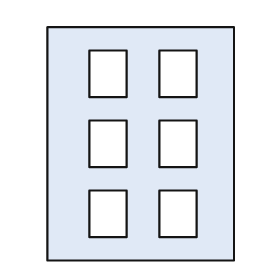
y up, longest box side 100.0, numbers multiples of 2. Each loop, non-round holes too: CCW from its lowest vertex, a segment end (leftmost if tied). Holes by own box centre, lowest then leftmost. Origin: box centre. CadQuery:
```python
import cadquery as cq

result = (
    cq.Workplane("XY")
    .moveTo(-40.0, -50.0)
    .lineTo(40.0, -50.0)
    .lineTo(40.0, 50.0)
    .lineTo(-40.0, 50.0)
    .close()
    .moveTo(-22.0, -40.0)
    .lineTo(-6.0, -40.0)
    .lineTo(-6.0, -20.0)
    .lineTo(-22.0, -20.0)
    .close()
    .moveTo(8.0, -40.0)
    .lineTo(24.0, -40.0)
    .lineTo(24.0, -20.0)
    .lineTo(8.0, -20.0)
    .close()
    .moveTo(-22.0, -10.0)
    .lineTo(-6.0, -10.0)
    .lineTo(-6.0, 10.0)
    .lineTo(-22.0, 10.0)
    .close()
    .moveTo(8.0, -10.0)
    .lineTo(24.0, -10.0)
    .lineTo(24.0, 10.0)
    .lineTo(8.0, 10.0)
    .close()
    .moveTo(-22.0, 20.0)
    .lineTo(-6.0, 20.0)
    .lineTo(-6.0, 40.0)
    .lineTo(-22.0, 40.0)
    .close()
    .moveTo(8.0, 20.0)
    .lineTo(24.0, 20.0)
    .lineTo(24.0, 40.0)
    .lineTo(8.0, 40.0)
    .close()
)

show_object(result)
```